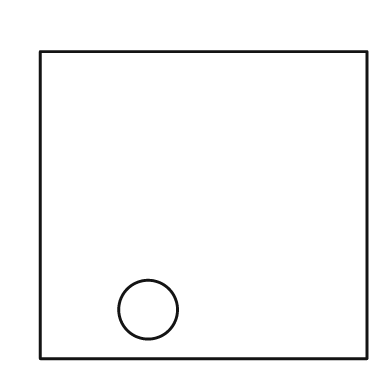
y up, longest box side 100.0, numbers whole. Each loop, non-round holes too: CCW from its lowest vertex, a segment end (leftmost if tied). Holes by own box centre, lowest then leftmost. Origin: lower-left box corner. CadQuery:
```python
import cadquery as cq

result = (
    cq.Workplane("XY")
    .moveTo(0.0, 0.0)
    .lineTo(100.0, 0.0)
    .lineTo(100.0, 94.0)
    .lineTo(0.0, 94.0)
    .close()
    .moveTo(33.0, 15.0)
    .circle(9.0)
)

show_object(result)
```